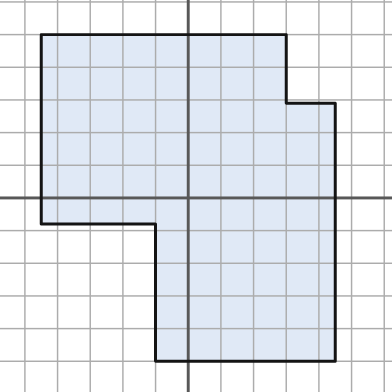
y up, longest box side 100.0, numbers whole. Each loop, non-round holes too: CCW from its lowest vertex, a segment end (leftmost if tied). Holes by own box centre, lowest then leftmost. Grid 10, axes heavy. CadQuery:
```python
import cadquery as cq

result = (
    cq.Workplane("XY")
    .moveTo(-10.0, -50.0)
    .lineTo(45.0, -50.0)
    .lineTo(45.0, 29.0)
    .lineTo(30.0, 29.0)
    .lineTo(30.0, 50.0)
    .lineTo(-45.0, 50.0)
    .lineTo(-45.0, -8.0)
    .lineTo(-10.0, -8.0)
    .close()
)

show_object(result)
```